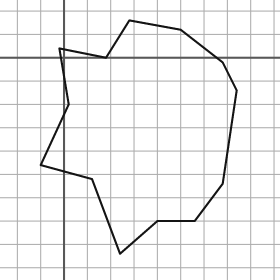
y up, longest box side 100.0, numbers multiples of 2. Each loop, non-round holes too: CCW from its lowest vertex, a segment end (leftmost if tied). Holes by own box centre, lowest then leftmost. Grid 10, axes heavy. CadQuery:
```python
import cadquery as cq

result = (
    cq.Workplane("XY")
    .moveTo(24.0, -84.0)
    .lineTo(40.0, -70.0)
    .lineTo(56.0, -70.0)
    .lineTo(68.0, -54.0)
    .lineTo(74.0, -14.0)
    .lineTo(68.0, -2.0)
    .lineTo(50.0, 12.0)
    .lineTo(28.0, 16.0)
    .lineTo(18.0, 0.0)
    .lineTo(-2.0, 4.0)
    .lineTo(2.0, -20.0)
    .lineTo(-10.0, -46.0)
    .lineTo(12.0, -52.0)
    .close()
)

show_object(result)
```